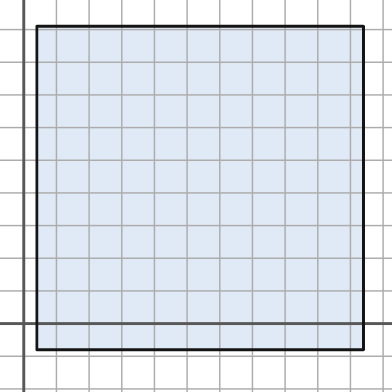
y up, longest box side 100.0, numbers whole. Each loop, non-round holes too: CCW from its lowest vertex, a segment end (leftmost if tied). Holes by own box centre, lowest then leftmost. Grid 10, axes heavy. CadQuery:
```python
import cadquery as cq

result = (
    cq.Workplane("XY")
    .moveTo(4.0, -8.0)
    .lineTo(104.0, -8.0)
    .lineTo(104.0, 91.0)
    .lineTo(4.0, 91.0)
    .close()
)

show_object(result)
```